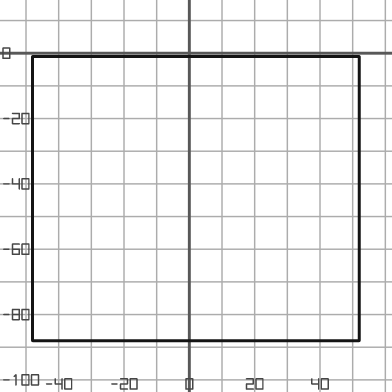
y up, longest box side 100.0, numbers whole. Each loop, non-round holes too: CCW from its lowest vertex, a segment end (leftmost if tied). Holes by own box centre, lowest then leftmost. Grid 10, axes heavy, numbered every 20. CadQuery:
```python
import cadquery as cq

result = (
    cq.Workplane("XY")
    .moveTo(-48.0, -88.0)
    .lineTo(52.0, -88.0)
    .lineTo(52.0, -1.0)
    .lineTo(-48.0, -1.0)
    .close()
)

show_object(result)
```